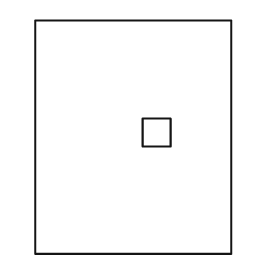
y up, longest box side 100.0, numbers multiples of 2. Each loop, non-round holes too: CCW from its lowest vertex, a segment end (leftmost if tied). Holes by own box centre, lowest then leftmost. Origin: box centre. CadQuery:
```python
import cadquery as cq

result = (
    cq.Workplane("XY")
    .moveTo(-42.0, -50.0)
    .lineTo(42.0, -50.0)
    .lineTo(42.0, 50.0)
    .lineTo(-42.0, 50.0)
    .close()
    .moveTo(4.0, -4.0)
    .lineTo(16.0, -4.0)
    .lineTo(16.0, 8.0)
    .lineTo(4.0, 8.0)
    .close()
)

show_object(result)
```